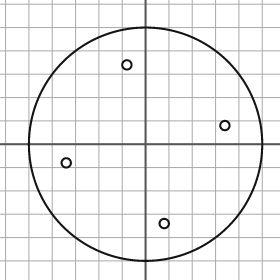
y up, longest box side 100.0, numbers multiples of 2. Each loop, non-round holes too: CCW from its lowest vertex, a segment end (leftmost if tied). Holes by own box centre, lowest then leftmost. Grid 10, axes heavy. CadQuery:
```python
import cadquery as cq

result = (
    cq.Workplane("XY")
    .moveTo(0.0, 0.0)
    .circle(50.0)
    .moveTo(8.0, -34.0)
    .circle(2.0)
    .moveTo(-34.0, -8.0)
    .circle(2.0)
    .moveTo(34.0, 8.0)
    .circle(2.0)
    .moveTo(-8.0, 34.0)
    .circle(2.0)
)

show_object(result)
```